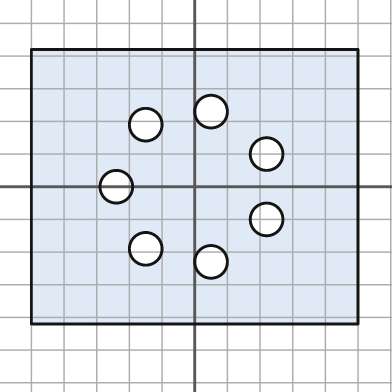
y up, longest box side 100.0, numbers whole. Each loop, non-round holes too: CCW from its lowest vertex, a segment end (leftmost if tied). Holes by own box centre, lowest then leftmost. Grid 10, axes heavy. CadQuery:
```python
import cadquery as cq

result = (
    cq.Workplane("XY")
    .moveTo(-50.0, -42.0)
    .lineTo(50.0, -42.0)
    .lineTo(50.0, 42.0)
    .lineTo(-50.0, 42.0)
    .close()
    .moveTo(5.0, -23.0)
    .circle(5.0)
    .moveTo(-15.0, -19.0)
    .circle(5.0)
    .moveTo(22.0, -10.0)
    .circle(5.0)
    .moveTo(-24.0, 0.0)
    .circle(5.0)
    .moveTo(22.0, 10.0)
    .circle(5.0)
    .moveTo(-15.0, 19.0)
    .circle(5.0)
    .moveTo(5.0, 23.0)
    .circle(5.0)
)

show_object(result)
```